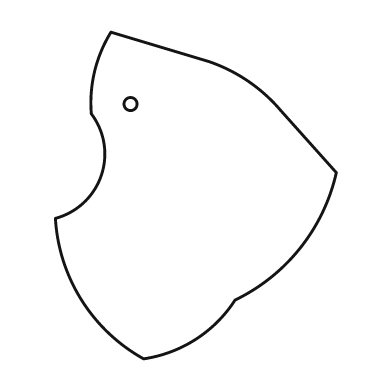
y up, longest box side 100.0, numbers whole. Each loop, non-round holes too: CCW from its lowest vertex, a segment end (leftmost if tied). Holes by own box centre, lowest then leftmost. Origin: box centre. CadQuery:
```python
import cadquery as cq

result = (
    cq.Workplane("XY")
    .moveTo(-16.0, -50.0)
    .threePointArc((0.0, -44.0), (12.0, -32.0))
    .threePointArc((32.0, -16.0), (43.0, 7.0))
    .lineTo(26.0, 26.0)
    .threePointArc((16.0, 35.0), (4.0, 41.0))
    .lineTo(-26.0, 50.0)
    .threePointArc((-31.0, 38.0), (-32.0, 25.0))
    .threePointArc((-29.0, 6.0), (-43.0, -7.0))
    .threePointArc((-35.0, -32.0), (-16.0, -50.0))
    .close()
    .moveTo(-20.0, 28.0)
    .circle(2.0)
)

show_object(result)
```